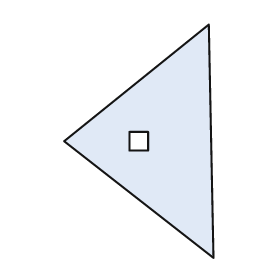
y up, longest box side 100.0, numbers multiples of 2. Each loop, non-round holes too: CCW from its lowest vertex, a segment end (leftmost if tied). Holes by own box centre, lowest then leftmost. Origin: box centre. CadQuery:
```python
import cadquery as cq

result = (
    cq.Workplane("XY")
    .moveTo(32.0, -50.0)
    .lineTo(30.0, 50.0)
    .lineTo(-32.0, 0.0)
    .close()
    .moveTo(-4.0, -4.0)
    .lineTo(4.0, -4.0)
    .lineTo(4.0, 4.0)
    .lineTo(-4.0, 4.0)
    .close()
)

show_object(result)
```